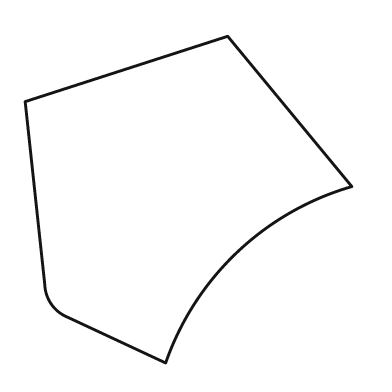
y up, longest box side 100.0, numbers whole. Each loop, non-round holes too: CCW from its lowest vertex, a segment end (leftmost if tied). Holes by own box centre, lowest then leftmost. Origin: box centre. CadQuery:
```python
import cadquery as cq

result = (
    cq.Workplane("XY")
    .moveTo(-7.0, -50.0)
    .threePointArc((15.0, -16.0), (50.0, 4.0))
    .lineTo(12.0, 50.0)
    .lineTo(-50.0, 30.0)
    .lineTo(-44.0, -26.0)
    .threePointArc((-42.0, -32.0), (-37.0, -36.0))
    .close()
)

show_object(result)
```